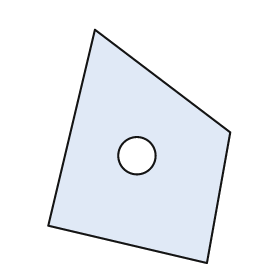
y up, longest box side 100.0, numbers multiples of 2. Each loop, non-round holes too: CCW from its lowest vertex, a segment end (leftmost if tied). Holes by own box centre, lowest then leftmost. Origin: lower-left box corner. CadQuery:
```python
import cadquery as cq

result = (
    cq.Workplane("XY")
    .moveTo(68.0, 0.0)
    .lineTo(78.0, 56.0)
    .lineTo(20.0, 100.0)
    .lineTo(0.0, 16.0)
    .close()
    .moveTo(38.0, 46.0)
    .circle(8.0)
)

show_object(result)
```